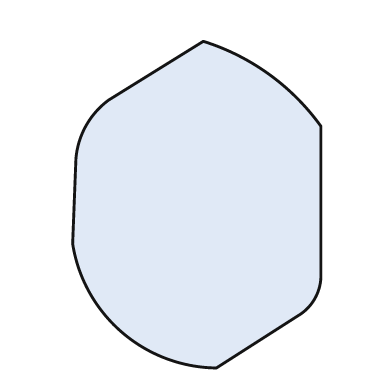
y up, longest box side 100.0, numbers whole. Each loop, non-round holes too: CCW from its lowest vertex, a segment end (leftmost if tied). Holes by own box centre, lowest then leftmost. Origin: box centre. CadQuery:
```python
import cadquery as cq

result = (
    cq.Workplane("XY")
    .moveTo(6.0, -50.0)
    .lineTo(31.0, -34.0)
    .threePointArc((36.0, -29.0), (38.0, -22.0))
    .lineTo(38.0, 24.0)
    .threePointArc((22.0, 40.0), (2.0, 50.0))
    .lineTo(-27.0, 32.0)
    .threePointArc((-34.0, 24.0), (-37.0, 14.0))
    .lineTo(-38.0, -12.0)
    .threePointArc((-23.0, -39.0), (6.0, -50.0))
    .close()
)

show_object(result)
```